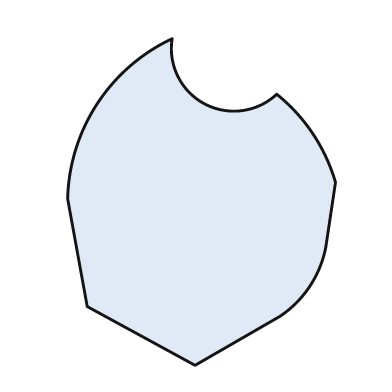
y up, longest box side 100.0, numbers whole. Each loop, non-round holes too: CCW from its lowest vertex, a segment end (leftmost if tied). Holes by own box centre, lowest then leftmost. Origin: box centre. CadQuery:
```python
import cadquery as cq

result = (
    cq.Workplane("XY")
    .moveTo(-2.0, -50.0)
    .lineTo(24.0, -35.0)
    .threePointArc((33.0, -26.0), (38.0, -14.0))
    .lineTo(41.0, 6.0)
    .threePointArc((34.0, 21.0), (23.0, 33.0))
    .threePointArc((1.0, 30.0), (-9.0, 50.0))
    .threePointArc((-32.0, 30.0), (-41.0, 1.0))
    .lineTo(-35.0, -32.0)
    .close()
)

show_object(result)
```